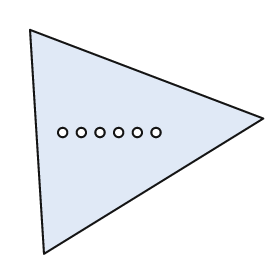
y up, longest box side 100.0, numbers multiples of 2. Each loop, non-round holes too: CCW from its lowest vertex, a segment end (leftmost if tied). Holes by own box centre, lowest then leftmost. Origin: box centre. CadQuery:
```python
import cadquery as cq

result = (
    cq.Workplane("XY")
    .moveTo(-44.0, -48.0)
    .lineTo(50.0, 10.0)
    .lineTo(-50.0, 48.0)
    .close()
    .moveTo(-36.0, 4.0)
    .circle(2.0)
    .moveTo(-28.0, 4.0)
    .circle(2.0)
    .moveTo(-20.0, 4.0)
    .circle(2.0)
    .moveTo(-12.0, 4.0)
    .circle(2.0)
    .moveTo(-4.0, 4.0)
    .circle(2.0)
    .moveTo(4.0, 4.0)
    .circle(2.0)
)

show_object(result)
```